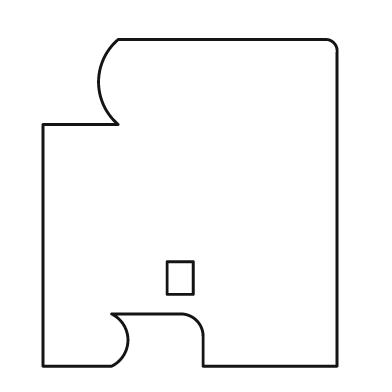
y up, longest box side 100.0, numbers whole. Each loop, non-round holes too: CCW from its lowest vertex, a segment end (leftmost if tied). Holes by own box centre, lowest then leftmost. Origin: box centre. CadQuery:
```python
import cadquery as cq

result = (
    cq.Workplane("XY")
    .moveTo(-45.0, -50.0)
    .lineTo(-24.0, -50.0)
    .threePointArc((-19.0, -42.0), (-24.0, -34.0))
    .lineTo(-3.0, -34.0)
    .threePointArc((2.0, -36.0), (4.0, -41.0))
    .lineTo(4.0, -50.0)
    .lineTo(45.0, -50.0)
    .lineTo(45.0, 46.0)
    .threePointArc((44.0, 49.0), (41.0, 50.0))
    .lineTo(-22.0, 50.0)
    .threePointArc((-28.0, 37.0), (-22.0, 24.0))
    .lineTo(-45.0, 24.0)
    .close()
    .moveTo(-7.0, -28.0)
    .lineTo(1.0, -28.0)
    .lineTo(1.0, -18.0)
    .lineTo(-7.0, -18.0)
    .close()
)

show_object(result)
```